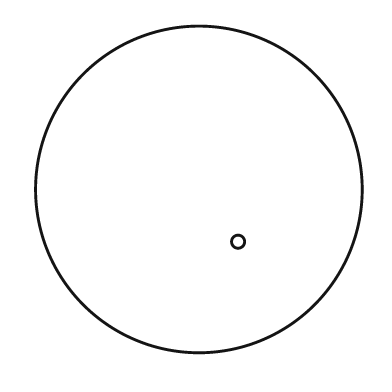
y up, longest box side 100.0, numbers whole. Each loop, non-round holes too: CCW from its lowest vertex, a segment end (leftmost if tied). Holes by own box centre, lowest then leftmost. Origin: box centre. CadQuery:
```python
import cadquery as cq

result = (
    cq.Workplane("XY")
    .moveTo(0.0, 0.0)
    .circle(50.0)
    .moveTo(12.0, -16.0)
    .circle(2.0)
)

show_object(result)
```